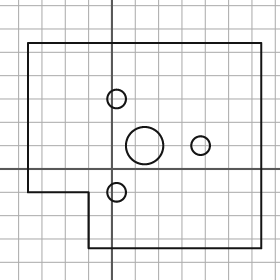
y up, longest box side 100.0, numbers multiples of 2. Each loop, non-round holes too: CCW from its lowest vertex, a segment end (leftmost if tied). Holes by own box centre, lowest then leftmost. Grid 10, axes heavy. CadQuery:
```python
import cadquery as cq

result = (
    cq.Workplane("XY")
    .moveTo(-10.0, -34.0)
    .lineTo(64.0, -34.0)
    .lineTo(64.0, 54.0)
    .lineTo(-36.0, 54.0)
    .lineTo(-36.0, -10.0)
    .lineTo(-10.0, -10.0)
    .close()
    .moveTo(2.0, -10.0)
    .circle(4.0)
    .moveTo(14.0, 10.0)
    .circle(8.0)
    .moveTo(38.0, 10.0)
    .circle(4.0)
    .moveTo(2.0, 30.0)
    .circle(4.0)
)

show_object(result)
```